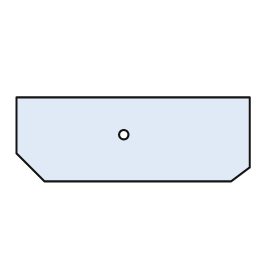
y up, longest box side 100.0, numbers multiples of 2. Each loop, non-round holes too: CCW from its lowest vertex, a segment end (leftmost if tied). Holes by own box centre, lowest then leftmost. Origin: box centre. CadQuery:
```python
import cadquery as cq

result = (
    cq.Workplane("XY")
    .moveTo(-38.0, -18.0)
    .lineTo(42.0, -18.0)
    .lineTo(50.0, -12.0)
    .lineTo(50.0, 18.0)
    .lineTo(-50.0, 18.0)
    .lineTo(-50.0, -6.0)
    .close()
    .moveTo(-4.0, 2.0)
    .circle(2.0)
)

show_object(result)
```